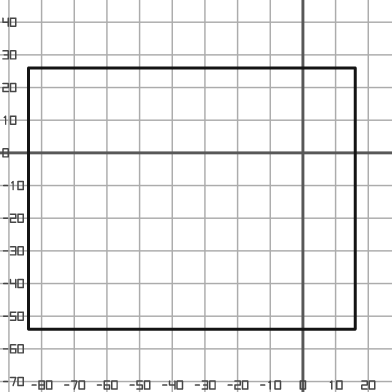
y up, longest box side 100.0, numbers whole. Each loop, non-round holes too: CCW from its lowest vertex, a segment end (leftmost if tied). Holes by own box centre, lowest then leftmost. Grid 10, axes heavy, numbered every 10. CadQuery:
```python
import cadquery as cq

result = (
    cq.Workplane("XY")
    .moveTo(-84.0, -54.0)
    .lineTo(16.0, -54.0)
    .lineTo(16.0, 26.0)
    .lineTo(-84.0, 26.0)
    .close()
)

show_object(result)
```